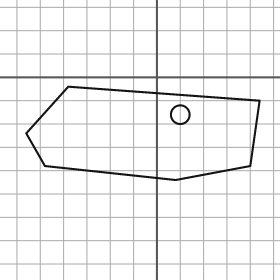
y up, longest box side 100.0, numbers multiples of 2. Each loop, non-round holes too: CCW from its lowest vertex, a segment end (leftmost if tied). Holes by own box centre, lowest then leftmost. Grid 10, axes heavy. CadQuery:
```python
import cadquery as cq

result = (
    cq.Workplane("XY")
    .moveTo(8.0, -44.0)
    .lineTo(40.0, -38.0)
    .lineTo(44.0, -10.0)
    .lineTo(-38.0, -4.0)
    .lineTo(-56.0, -24.0)
    .lineTo(-48.0, -38.0)
    .close()
    .moveTo(10.0, -16.0)
    .circle(4.0)
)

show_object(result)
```